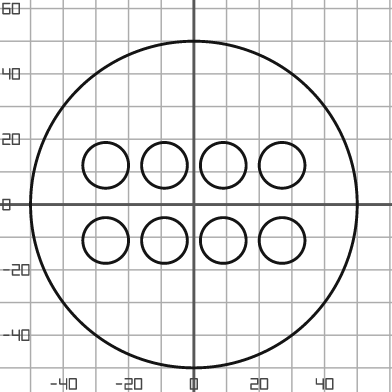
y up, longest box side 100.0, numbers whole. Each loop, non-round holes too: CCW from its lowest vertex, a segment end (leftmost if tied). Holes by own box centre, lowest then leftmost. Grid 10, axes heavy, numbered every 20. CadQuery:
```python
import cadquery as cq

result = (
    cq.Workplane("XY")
    .moveTo(0.0, 0.0)
    .circle(50.0)
    .moveTo(-27.0, -11.0)
    .circle(7.0)
    .moveTo(-9.0, -11.0)
    .circle(7.0)
    .moveTo(9.0, -11.0)
    .circle(7.0)
    .moveTo(27.0, -11.0)
    .circle(7.0)
    .moveTo(-27.0, 12.0)
    .circle(7.0)
    .moveTo(-9.0, 12.0)
    .circle(7.0)
    .moveTo(9.0, 12.0)
    .circle(7.0)
    .moveTo(27.0, 12.0)
    .circle(7.0)
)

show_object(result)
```